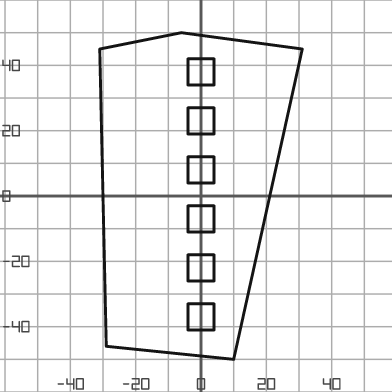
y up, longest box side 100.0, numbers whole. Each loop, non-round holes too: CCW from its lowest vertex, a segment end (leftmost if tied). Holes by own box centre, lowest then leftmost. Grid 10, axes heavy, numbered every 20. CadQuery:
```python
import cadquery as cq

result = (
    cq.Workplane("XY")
    .moveTo(10.0, -50.0)
    .lineTo(31.0, 45.0)
    .lineTo(-6.0, 50.0)
    .lineTo(-31.0, 45.0)
    .lineTo(-29.0, -46.0)
    .close()
    .moveTo(-4.0, -41.0)
    .lineTo(4.0, -41.0)
    .lineTo(4.0, -33.0)
    .lineTo(-4.0, -33.0)
    .close()
    .moveTo(-4.0, -26.0)
    .lineTo(4.0, -26.0)
    .lineTo(4.0, -18.0)
    .lineTo(-4.0, -18.0)
    .close()
    .moveTo(-4.0, -11.0)
    .lineTo(4.0, -11.0)
    .lineTo(4.0, -3.0)
    .lineTo(-4.0, -3.0)
    .close()
    .moveTo(-4.0, 4.0)
    .lineTo(4.0, 4.0)
    .lineTo(4.0, 12.0)
    .lineTo(-4.0, 12.0)
    .close()
    .moveTo(-4.0, 19.0)
    .lineTo(4.0, 19.0)
    .lineTo(4.0, 27.0)
    .lineTo(-4.0, 27.0)
    .close()
    .moveTo(-4.0, 34.0)
    .lineTo(4.0, 34.0)
    .lineTo(4.0, 42.0)
    .lineTo(-4.0, 42.0)
    .close()
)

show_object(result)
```